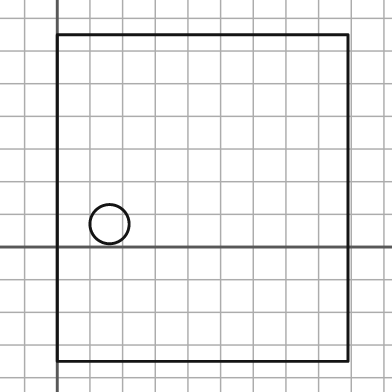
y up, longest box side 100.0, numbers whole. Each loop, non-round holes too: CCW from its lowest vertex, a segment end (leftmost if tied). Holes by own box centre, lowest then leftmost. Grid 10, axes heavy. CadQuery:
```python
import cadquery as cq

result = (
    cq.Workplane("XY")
    .moveTo(0.0, -35.0)
    .lineTo(89.0, -35.0)
    .lineTo(89.0, 65.0)
    .lineTo(0.0, 65.0)
    .close()
    .moveTo(16.0, 7.0)
    .circle(6.0)
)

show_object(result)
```